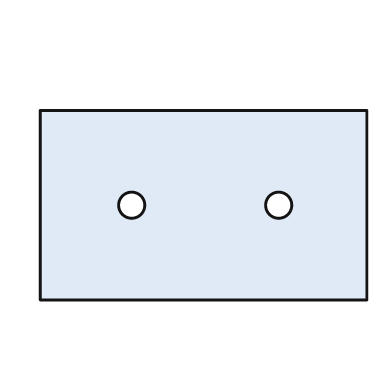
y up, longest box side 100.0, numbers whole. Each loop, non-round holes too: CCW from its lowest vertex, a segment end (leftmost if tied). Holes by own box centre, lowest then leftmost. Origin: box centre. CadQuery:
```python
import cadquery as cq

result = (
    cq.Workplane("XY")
    .moveTo(-50.0, -29.0)
    .lineTo(50.0, -29.0)
    .lineTo(50.0, 29.0)
    .lineTo(-50.0, 29.0)
    .close()
    .moveTo(-22.0, 0.0)
    .circle(4.0)
    .moveTo(23.0, 0.0)
    .circle(4.0)
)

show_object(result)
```